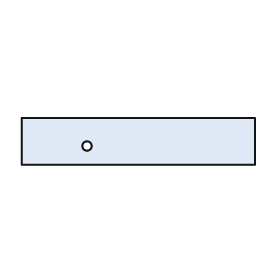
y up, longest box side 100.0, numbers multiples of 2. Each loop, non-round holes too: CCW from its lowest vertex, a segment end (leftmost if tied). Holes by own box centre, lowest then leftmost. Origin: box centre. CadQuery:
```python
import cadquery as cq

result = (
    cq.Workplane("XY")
    .moveTo(-50.0, -10.0)
    .lineTo(50.0, -10.0)
    .lineTo(50.0, 10.0)
    .lineTo(-50.0, 10.0)
    .close()
    .moveTo(-22.0, -2.0)
    .circle(2.0)
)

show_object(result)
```